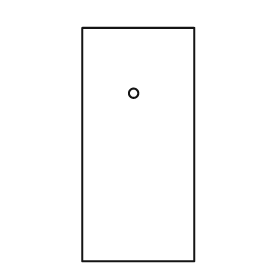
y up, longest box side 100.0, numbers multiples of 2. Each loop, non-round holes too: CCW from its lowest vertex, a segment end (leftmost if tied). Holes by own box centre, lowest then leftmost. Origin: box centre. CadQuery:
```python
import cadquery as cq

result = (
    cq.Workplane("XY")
    .moveTo(-24.0, -50.0)
    .lineTo(24.0, -50.0)
    .lineTo(24.0, 50.0)
    .lineTo(-24.0, 50.0)
    .close()
    .moveTo(-2.0, 22.0)
    .circle(2.0)
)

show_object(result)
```